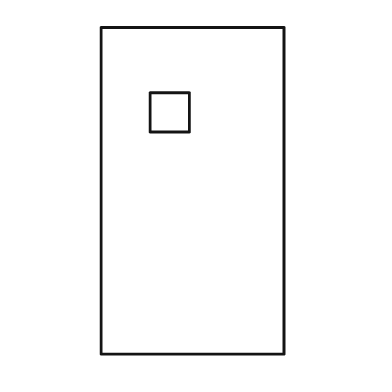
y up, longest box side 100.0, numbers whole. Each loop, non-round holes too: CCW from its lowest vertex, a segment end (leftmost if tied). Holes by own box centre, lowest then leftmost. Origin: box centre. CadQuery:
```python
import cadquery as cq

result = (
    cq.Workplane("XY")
    .moveTo(-28.0, -50.0)
    .lineTo(28.0, -50.0)
    .lineTo(28.0, 50.0)
    .lineTo(-28.0, 50.0)
    .close()
    .moveTo(-13.0, 18.0)
    .lineTo(-1.0, 18.0)
    .lineTo(-1.0, 30.0)
    .lineTo(-13.0, 30.0)
    .close()
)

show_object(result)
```